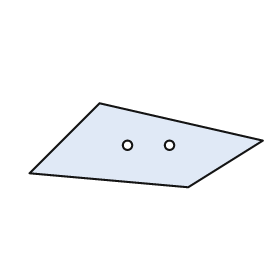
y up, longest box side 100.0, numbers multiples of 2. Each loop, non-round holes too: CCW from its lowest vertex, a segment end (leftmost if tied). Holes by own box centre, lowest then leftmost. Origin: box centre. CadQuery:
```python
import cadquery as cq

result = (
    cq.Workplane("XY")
    .moveTo(18.0, -18.0)
    .lineTo(50.0, 2.0)
    .lineTo(-20.0, 18.0)
    .lineTo(-50.0, -12.0)
    .close()
    .moveTo(-8.0, 0.0)
    .circle(2.0)
    .moveTo(10.0, 0.0)
    .circle(2.0)
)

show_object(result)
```